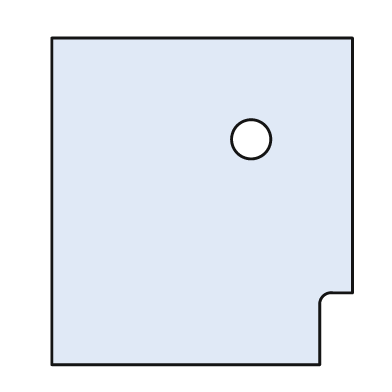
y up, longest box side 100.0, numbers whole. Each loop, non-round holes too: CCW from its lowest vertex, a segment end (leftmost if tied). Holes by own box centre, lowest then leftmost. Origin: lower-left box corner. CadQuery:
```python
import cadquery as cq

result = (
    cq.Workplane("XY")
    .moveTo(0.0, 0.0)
    .lineTo(82.0, 0.0)
    .lineTo(82.0, 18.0)
    .threePointArc((83.0, 21.0), (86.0, 22.0))
    .lineTo(92.0, 22.0)
    .lineTo(92.0, 100.0)
    .lineTo(0.0, 100.0)
    .close()
    .moveTo(61.0, 69.0)
    .circle(6.0)
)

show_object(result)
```